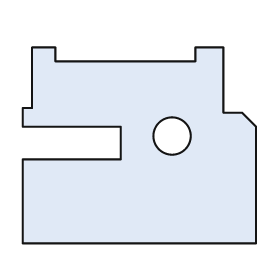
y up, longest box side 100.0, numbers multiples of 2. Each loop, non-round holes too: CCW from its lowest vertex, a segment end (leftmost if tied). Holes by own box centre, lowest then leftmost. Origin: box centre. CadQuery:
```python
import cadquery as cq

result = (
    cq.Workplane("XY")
    .moveTo(-50.0, -42.0)
    .lineTo(50.0, -42.0)
    .lineTo(50.0, 8.0)
    .lineTo(44.0, 14.0)
    .lineTo(36.0, 14.0)
    .lineTo(36.0, 42.0)
    .lineTo(24.0, 42.0)
    .lineTo(24.0, 36.0)
    .lineTo(-36.0, 36.0)
    .lineTo(-36.0, 42.0)
    .lineTo(-46.0, 42.0)
    .lineTo(-46.0, 16.0)
    .lineTo(-50.0, 16.0)
    .lineTo(-50.0, 8.0)
    .lineTo(-8.0, 8.0)
    .lineTo(-8.0, -6.0)
    .lineTo(-50.0, -6.0)
    .close()
    .moveTo(14.0, 4.0)
    .circle(8.0)
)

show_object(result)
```